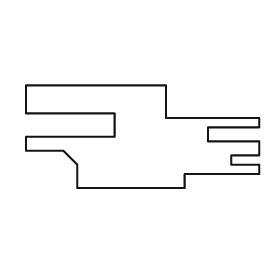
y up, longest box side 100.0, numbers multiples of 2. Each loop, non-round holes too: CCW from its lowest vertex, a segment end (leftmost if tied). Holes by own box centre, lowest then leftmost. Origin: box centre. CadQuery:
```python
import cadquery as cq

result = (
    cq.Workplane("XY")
    .moveTo(-28.0, -22.0)
    .lineTo(18.0, -22.0)
    .lineTo(18.0, -16.0)
    .lineTo(50.0, -16.0)
    .lineTo(50.0, -12.0)
    .lineTo(38.0, -12.0)
    .lineTo(38.0, -8.0)
    .lineTo(50.0, -8.0)
    .lineTo(50.0, -2.0)
    .lineTo(28.0, -2.0)
    .lineTo(28.0, 4.0)
    .lineTo(50.0, 4.0)
    .lineTo(50.0, 8.0)
    .lineTo(10.0, 8.0)
    .lineTo(10.0, 22.0)
    .lineTo(-50.0, 22.0)
    .lineTo(-50.0, 10.0)
    .lineTo(-12.0, 10.0)
    .lineTo(-12.0, 0.0)
    .lineTo(-50.0, 0.0)
    .lineTo(-50.0, -6.0)
    .lineTo(-34.0, -6.0)
    .lineTo(-28.0, -12.0)
    .close()
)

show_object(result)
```